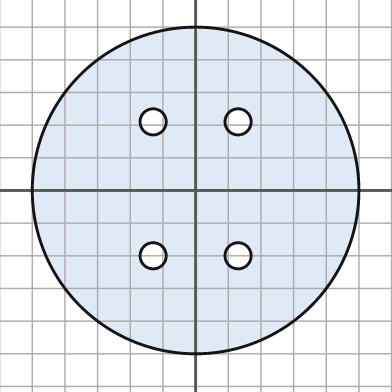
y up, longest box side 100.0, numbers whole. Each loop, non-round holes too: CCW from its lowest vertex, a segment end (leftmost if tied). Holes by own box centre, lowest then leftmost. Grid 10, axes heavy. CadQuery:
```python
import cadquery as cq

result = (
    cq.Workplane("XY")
    .moveTo(0.0, 0.0)
    .circle(50.0)
    .moveTo(-13.0, -20.0)
    .circle(4.0)
    .moveTo(13.0, -20.0)
    .circle(4.0)
    .moveTo(-13.0, 21.0)
    .circle(4.0)
    .moveTo(13.0, 21.0)
    .circle(4.0)
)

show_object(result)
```